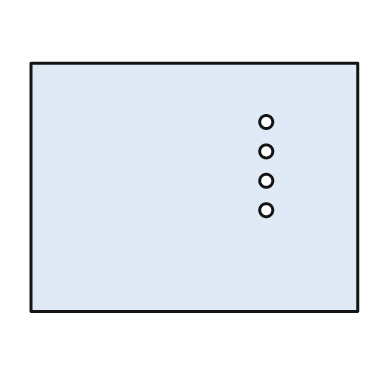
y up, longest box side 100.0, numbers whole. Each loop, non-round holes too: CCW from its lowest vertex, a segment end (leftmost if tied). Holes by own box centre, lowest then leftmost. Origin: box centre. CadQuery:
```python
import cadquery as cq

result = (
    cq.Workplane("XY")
    .moveTo(-50.0, -38.0)
    .lineTo(50.0, -38.0)
    .lineTo(50.0, 38.0)
    .lineTo(-50.0, 38.0)
    .close()
    .moveTo(22.0, -7.0)
    .circle(2.0)
    .moveTo(22.0, 2.0)
    .circle(2.0)
    .moveTo(22.0, 11.0)
    .circle(2.0)
    .moveTo(22.0, 20.0)
    .circle(2.0)
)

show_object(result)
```